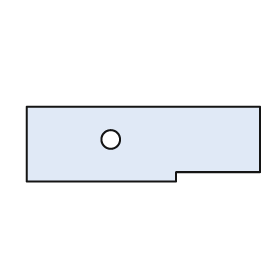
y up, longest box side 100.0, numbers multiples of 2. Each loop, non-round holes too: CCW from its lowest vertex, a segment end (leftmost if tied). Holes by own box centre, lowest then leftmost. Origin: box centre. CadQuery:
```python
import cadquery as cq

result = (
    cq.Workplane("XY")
    .moveTo(-50.0, -16.0)
    .lineTo(14.0, -16.0)
    .lineTo(14.0, -12.0)
    .lineTo(50.0, -12.0)
    .lineTo(50.0, 16.0)
    .lineTo(-50.0, 16.0)
    .close()
    .moveTo(-14.0, 2.0)
    .circle(4.0)
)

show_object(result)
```